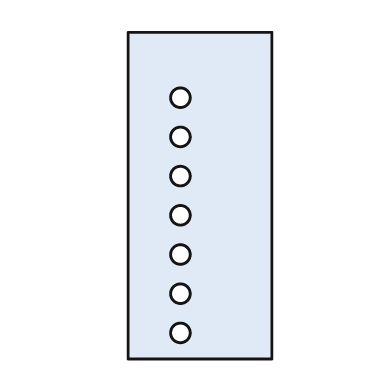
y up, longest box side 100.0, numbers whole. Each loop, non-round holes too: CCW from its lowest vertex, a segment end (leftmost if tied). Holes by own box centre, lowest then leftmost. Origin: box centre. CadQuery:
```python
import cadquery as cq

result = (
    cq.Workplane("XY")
    .moveTo(-22.0, -50.0)
    .lineTo(22.0, -50.0)
    .lineTo(22.0, 50.0)
    .lineTo(-22.0, 50.0)
    .close()
    .moveTo(-6.0, -42.0)
    .circle(3.0)
    .moveTo(-6.0, -30.0)
    .circle(3.0)
    .moveTo(-6.0, -18.0)
    .circle(3.0)
    .moveTo(-6.0, -6.0)
    .circle(3.0)
    .moveTo(-6.0, 6.0)
    .circle(3.0)
    .moveTo(-6.0, 18.0)
    .circle(3.0)
    .moveTo(-6.0, 30.0)
    .circle(3.0)
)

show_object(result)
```